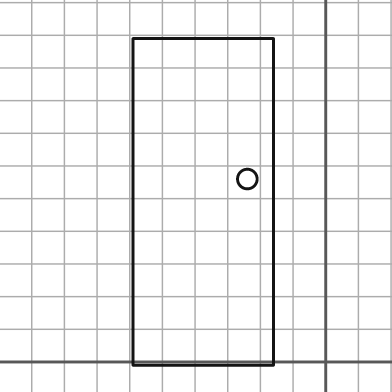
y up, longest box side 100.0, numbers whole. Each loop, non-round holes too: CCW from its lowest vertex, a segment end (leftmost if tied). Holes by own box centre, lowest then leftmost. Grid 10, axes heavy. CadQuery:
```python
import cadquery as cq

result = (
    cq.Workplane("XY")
    .moveTo(-59.0, -1.0)
    .lineTo(-16.0, -1.0)
    .lineTo(-16.0, 99.0)
    .lineTo(-59.0, 99.0)
    .close()
    .moveTo(-24.0, 56.0)
    .circle(3.0)
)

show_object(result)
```